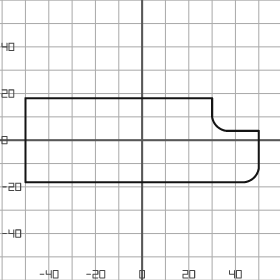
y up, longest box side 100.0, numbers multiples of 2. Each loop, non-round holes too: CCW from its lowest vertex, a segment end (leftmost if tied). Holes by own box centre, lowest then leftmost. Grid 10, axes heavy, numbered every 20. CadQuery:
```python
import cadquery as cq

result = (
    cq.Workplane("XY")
    .moveTo(-50.0, -18.0)
    .lineTo(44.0, -18.0)
    .threePointArc((48.0, -16.0), (50.0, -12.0))
    .lineTo(50.0, 4.0)
    .lineTo(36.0, 4.0)
    .threePointArc((32.0, 6.0), (30.0, 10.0))
    .lineTo(30.0, 18.0)
    .lineTo(-50.0, 18.0)
    .close()
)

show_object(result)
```